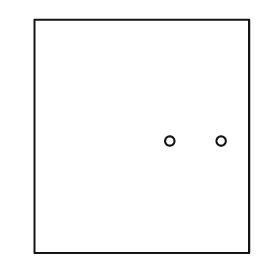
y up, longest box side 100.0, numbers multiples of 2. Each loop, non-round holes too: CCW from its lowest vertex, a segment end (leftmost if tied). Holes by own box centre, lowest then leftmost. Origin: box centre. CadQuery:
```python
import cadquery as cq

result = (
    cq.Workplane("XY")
    .moveTo(-46.0, -50.0)
    .lineTo(46.0, -50.0)
    .lineTo(46.0, 50.0)
    .lineTo(-46.0, 50.0)
    .close()
    .moveTo(12.0, -2.0)
    .circle(2.0)
    .moveTo(34.0, -2.0)
    .circle(2.0)
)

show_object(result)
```